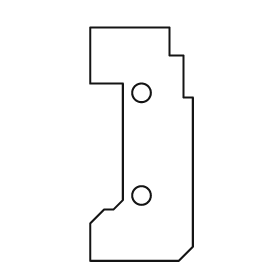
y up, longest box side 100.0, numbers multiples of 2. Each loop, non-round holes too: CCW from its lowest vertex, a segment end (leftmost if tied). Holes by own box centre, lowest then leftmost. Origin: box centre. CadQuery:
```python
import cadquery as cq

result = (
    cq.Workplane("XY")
    .moveTo(-22.0, -50.0)
    .lineTo(16.0, -50.0)
    .lineTo(22.0, -44.0)
    .lineTo(22.0, 20.0)
    .lineTo(18.0, 20.0)
    .lineTo(18.0, 38.0)
    .lineTo(12.0, 38.0)
    .lineTo(12.0, 50.0)
    .lineTo(-22.0, 50.0)
    .lineTo(-22.0, 26.0)
    .lineTo(-8.0, 26.0)
    .lineTo(-8.0, -24.0)
    .lineTo(-12.0, -28.0)
    .lineTo(-16.0, -28.0)
    .lineTo(-22.0, -34.0)
    .close()
    .moveTo(0.0, -22.0)
    .circle(4.0)
    .moveTo(0.0, 22.0)
    .circle(4.0)
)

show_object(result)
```